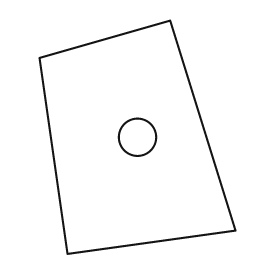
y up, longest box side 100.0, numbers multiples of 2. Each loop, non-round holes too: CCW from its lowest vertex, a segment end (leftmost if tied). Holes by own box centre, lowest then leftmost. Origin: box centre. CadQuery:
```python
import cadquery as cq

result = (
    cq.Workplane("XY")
    .moveTo(-30.0, -50.0)
    .lineTo(42.0, -40.0)
    .lineTo(14.0, 50.0)
    .lineTo(-42.0, 34.0)
    .close()
    .moveTo(0.0, 0.0)
    .circle(8.0)
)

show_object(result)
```